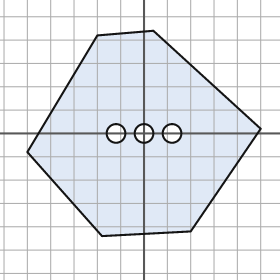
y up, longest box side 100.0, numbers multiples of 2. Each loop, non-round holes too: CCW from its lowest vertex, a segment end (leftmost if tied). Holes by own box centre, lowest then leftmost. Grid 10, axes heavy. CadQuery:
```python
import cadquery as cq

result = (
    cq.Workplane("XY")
    .moveTo(-18.0, -44.0)
    .lineTo(20.0, -42.0)
    .lineTo(50.0, 2.0)
    .lineTo(4.0, 44.0)
    .lineTo(-20.0, 42.0)
    .lineTo(-50.0, -8.0)
    .close()
    .moveTo(-12.0, 0.0)
    .circle(4.0)
    .moveTo(0.0, 0.0)
    .circle(4.0)
    .moveTo(12.0, 0.0)
    .circle(4.0)
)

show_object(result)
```